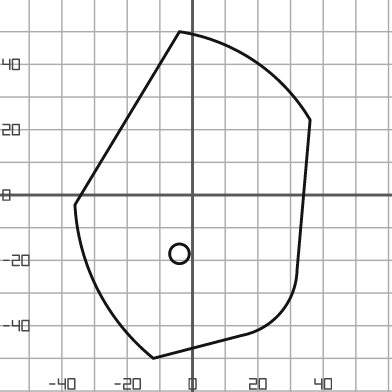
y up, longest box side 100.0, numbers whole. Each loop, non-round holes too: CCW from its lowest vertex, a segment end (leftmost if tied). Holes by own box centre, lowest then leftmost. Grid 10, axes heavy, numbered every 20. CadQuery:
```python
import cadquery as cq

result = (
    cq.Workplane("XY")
    .moveTo(-12.0, -50.0)
    .lineTo(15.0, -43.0)
    .threePointArc((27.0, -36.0), (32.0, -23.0))
    .lineTo(36.0, 23.0)
    .threePointArc((19.0, 41.0), (-4.0, 50.0))
    .lineTo(-36.0, -3.0)
    .threePointArc((-29.0, -29.0), (-12.0, -50.0))
    .close()
    .moveTo(-4.0, -18.0)
    .circle(3.0)
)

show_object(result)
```